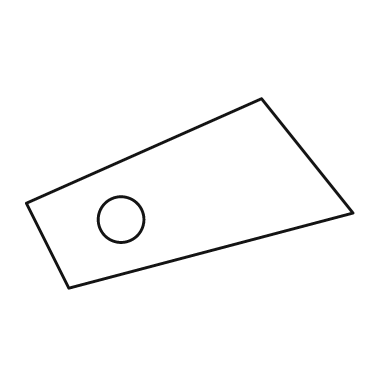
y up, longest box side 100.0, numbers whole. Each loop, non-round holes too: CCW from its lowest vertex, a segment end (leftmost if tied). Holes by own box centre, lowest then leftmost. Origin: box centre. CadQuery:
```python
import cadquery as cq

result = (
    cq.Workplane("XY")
    .moveTo(-37.0, -29.0)
    .lineTo(50.0, -6.0)
    .lineTo(22.0, 29.0)
    .lineTo(-50.0, -3.0)
    .close()
    .moveTo(-21.0, -8.0)
    .circle(7.0)
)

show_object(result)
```